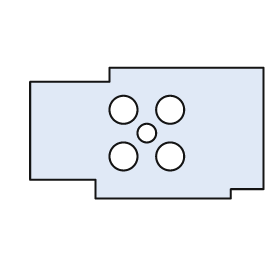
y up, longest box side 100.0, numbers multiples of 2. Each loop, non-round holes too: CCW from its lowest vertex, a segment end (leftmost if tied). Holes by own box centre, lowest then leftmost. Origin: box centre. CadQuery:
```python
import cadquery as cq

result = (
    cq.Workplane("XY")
    .moveTo(-22.0, -28.0)
    .lineTo(36.0, -28.0)
    .lineTo(36.0, -24.0)
    .lineTo(50.0, -24.0)
    .lineTo(50.0, 28.0)
    .lineTo(-16.0, 28.0)
    .lineTo(-16.0, 22.0)
    .lineTo(-50.0, 22.0)
    .lineTo(-50.0, -20.0)
    .lineTo(-22.0, -20.0)
    .close()
    .moveTo(-10.0, -10.0)
    .circle(6.0)
    .moveTo(10.0, -10.0)
    .circle(6.0)
    .moveTo(0.0, 0.0)
    .circle(4.0)
    .moveTo(-10.0, 10.0)
    .circle(6.0)
    .moveTo(10.0, 10.0)
    .circle(6.0)
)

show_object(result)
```